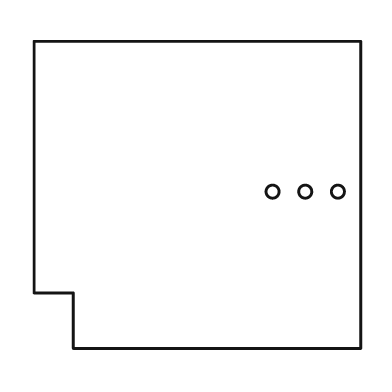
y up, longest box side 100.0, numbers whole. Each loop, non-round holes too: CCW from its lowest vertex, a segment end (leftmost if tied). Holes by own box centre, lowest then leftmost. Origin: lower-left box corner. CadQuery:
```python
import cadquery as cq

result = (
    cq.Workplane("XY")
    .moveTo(12.0, 0.0)
    .lineTo(100.0, 0.0)
    .lineTo(100.0, 94.0)
    .lineTo(0.0, 94.0)
    .lineTo(0.0, 17.0)
    .lineTo(12.0, 17.0)
    .close()
    .moveTo(73.0, 48.0)
    .circle(2.0)
    .moveTo(83.0, 48.0)
    .circle(2.0)
    .moveTo(93.0, 48.0)
    .circle(2.0)
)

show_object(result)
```